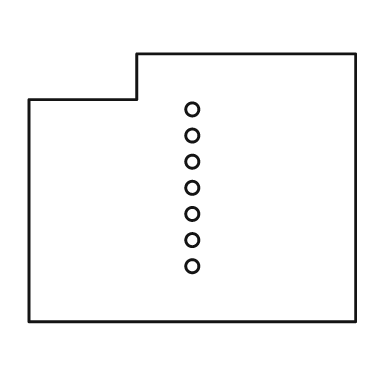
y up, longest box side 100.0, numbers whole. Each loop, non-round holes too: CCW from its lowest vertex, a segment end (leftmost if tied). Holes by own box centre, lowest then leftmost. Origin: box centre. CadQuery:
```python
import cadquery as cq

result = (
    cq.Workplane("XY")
    .moveTo(-50.0, -41.0)
    .lineTo(50.0, -41.0)
    .lineTo(50.0, 41.0)
    .lineTo(-17.0, 41.0)
    .lineTo(-17.0, 27.0)
    .lineTo(-50.0, 27.0)
    .close()
    .moveTo(0.0, -24.0)
    .circle(2.0)
    .moveTo(0.0, -16.0)
    .circle(2.0)
    .moveTo(0.0, -8.0)
    .circle(2.0)
    .moveTo(0.0, 0.0)
    .circle(2.0)
    .moveTo(0.0, 8.0)
    .circle(2.0)
    .moveTo(0.0, 16.0)
    .circle(2.0)
    .moveTo(0.0, 24.0)
    .circle(2.0)
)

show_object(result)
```